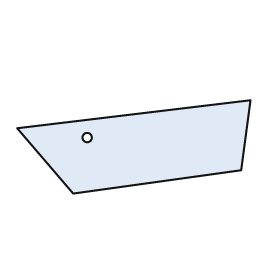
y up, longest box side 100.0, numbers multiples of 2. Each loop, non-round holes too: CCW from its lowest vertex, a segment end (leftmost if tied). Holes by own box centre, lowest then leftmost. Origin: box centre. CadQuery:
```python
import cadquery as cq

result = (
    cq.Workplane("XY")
    .moveTo(-26.0, -20.0)
    .lineTo(46.0, -10.0)
    .lineTo(50.0, 20.0)
    .lineTo(-50.0, 8.0)
    .close()
    .moveTo(-20.0, 4.0)
    .circle(2.0)
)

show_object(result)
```